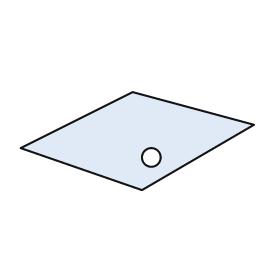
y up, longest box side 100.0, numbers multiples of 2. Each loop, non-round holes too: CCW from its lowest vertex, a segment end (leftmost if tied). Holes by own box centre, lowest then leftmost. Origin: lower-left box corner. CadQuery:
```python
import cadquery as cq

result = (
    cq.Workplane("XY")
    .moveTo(52.0, 0.0)
    .lineTo(100.0, 28.0)
    .lineTo(48.0, 42.0)
    .lineTo(0.0, 18.0)
    .close()
    .moveTo(56.0, 14.0)
    .circle(4.0)
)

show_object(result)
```